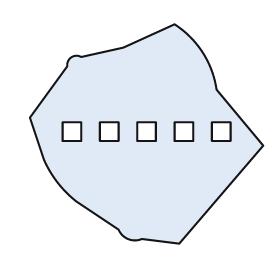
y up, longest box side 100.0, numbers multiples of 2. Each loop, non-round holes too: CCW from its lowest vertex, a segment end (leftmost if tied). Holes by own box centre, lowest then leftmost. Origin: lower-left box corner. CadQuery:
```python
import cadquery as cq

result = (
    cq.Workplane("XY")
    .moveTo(64.0, 0.0)
    .lineTo(100.0, 42.0)
    .lineTo(80.0, 66.0)
    .threePointArc((74.0, 82.0), (62.0, 94.0))
    .lineTo(40.0, 84.0)
    .lineTo(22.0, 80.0)
    .threePointArc((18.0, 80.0), (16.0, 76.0))
    .lineTo(0.0, 54.0)
    .lineTo(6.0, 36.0)
    .threePointArc((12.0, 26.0), (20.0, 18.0))
    .lineTo(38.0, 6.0)
    .threePointArc((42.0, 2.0), (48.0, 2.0))
    .close()
    .moveTo(14.0, 44.0)
    .lineTo(22.0, 44.0)
    .lineTo(22.0, 52.0)
    .lineTo(14.0, 52.0)
    .close()
    .moveTo(30.0, 44.0)
    .lineTo(38.0, 44.0)
    .lineTo(38.0, 52.0)
    .lineTo(30.0, 52.0)
    .close()
    .moveTo(46.0, 44.0)
    .lineTo(54.0, 44.0)
    .lineTo(54.0, 52.0)
    .lineTo(46.0, 52.0)
    .close()
    .moveTo(62.0, 44.0)
    .lineTo(70.0, 44.0)
    .lineTo(70.0, 52.0)
    .lineTo(62.0, 52.0)
    .close()
    .moveTo(78.0, 44.0)
    .lineTo(86.0, 44.0)
    .lineTo(86.0, 52.0)
    .lineTo(78.0, 52.0)
    .close()
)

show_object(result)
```